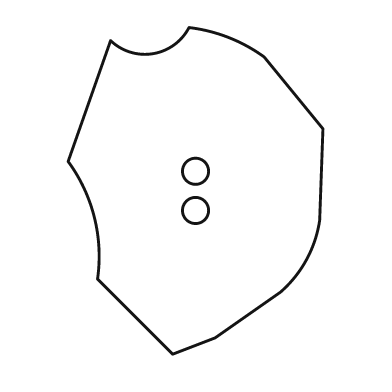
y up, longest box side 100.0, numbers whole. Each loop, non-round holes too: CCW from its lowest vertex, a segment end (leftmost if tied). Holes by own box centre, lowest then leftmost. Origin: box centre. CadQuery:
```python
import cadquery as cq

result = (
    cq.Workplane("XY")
    .moveTo(-7.0, -50.0)
    .lineTo(6.0, -45.0)
    .lineTo(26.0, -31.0)
    .threePointArc((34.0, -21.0), (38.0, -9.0))
    .lineTo(39.0, 19.0)
    .lineTo(21.0, 41.0)
    .threePointArc((10.0, 47.0), (-2.0, 50.0))
    .threePointArc((-13.0, 42.0), (-26.0, 46.0))
    .lineTo(-39.0, 9.0)
    .threePointArc((-31.0, -8.0), (-30.0, -27.0))
    .close()
    .moveTo(0.0, -6.0)
    .circle(4.0)
    .moveTo(0.0, 6.0)
    .circle(4.0)
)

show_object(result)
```